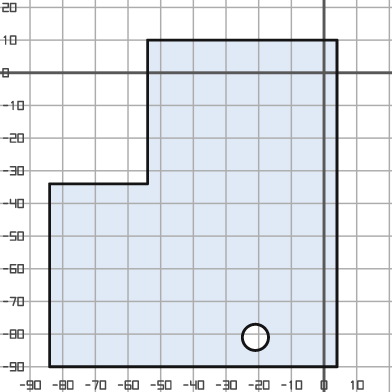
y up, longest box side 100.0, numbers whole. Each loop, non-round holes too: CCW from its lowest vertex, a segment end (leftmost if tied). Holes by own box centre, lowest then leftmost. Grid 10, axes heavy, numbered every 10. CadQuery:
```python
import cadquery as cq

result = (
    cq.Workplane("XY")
    .moveTo(-84.0, -90.0)
    .lineTo(4.0, -90.0)
    .lineTo(4.0, 10.0)
    .lineTo(-54.0, 10.0)
    .lineTo(-54.0, -34.0)
    .lineTo(-84.0, -34.0)
    .close()
    .moveTo(-21.0, -81.0)
    .circle(4.0)
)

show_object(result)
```